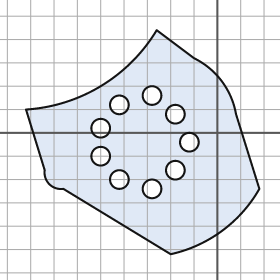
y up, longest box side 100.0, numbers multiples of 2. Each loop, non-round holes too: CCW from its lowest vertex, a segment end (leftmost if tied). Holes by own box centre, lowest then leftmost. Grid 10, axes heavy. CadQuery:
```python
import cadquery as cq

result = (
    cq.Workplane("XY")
    .moveTo(-20.0, -52.0)
    .threePointArc((2.0, -42.0), (18.0, -24.0))
    .lineTo(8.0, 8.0)
    .threePointArc((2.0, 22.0), (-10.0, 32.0))
    .lineTo(-26.0, 44.0)
    .threePointArc((-50.0, 20.0), (-82.0, 10.0))
    .lineTo(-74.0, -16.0)
    .threePointArc((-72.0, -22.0), (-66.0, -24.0))
    .close()
    .moveTo(-28.0, -24.0)
    .circle(4.0)
    .moveTo(-42.0, -20.0)
    .circle(4.0)
    .moveTo(-18.0, -16.0)
    .circle(4.0)
    .moveTo(-50.0, -10.0)
    .circle(4.0)
    .moveTo(-12.0, -4.0)
    .circle(4.0)
    .moveTo(-50.0, 2.0)
    .circle(4.0)
    .moveTo(-18.0, 8.0)
    .circle(4.0)
    .moveTo(-42.0, 12.0)
    .circle(4.0)
    .moveTo(-28.0, 16.0)
    .circle(4.0)
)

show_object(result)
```